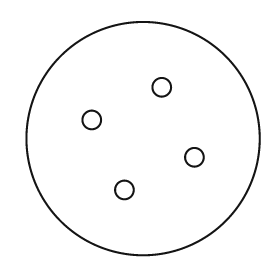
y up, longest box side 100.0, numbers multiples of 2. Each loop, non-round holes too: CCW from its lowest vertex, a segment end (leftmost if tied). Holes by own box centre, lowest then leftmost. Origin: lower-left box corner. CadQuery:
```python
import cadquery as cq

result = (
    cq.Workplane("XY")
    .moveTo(50.0, 50.0)
    .circle(50.0)
    .moveTo(42.0, 28.0)
    .circle(4.0)
    .moveTo(72.0, 42.0)
    .circle(4.0)
    .moveTo(28.0, 58.0)
    .circle(4.0)
    .moveTo(58.0, 72.0)
    .circle(4.0)
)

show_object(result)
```